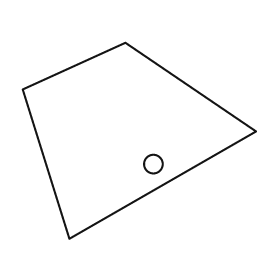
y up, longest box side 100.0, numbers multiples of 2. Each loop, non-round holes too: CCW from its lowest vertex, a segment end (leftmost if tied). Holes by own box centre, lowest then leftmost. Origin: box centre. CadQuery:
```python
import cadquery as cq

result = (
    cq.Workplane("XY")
    .moveTo(-30.0, -42.0)
    .lineTo(50.0, 4.0)
    .lineTo(-6.0, 42.0)
    .lineTo(-50.0, 22.0)
    .close()
    .moveTo(6.0, -10.0)
    .circle(4.0)
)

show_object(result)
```